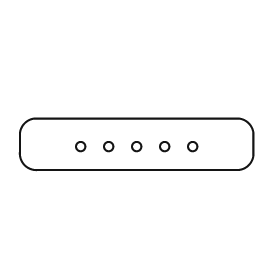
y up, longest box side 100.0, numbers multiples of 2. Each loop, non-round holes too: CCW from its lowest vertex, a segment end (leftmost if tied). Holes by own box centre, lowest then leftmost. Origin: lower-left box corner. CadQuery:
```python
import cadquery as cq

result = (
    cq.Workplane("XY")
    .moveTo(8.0, 0.0)
    .lineTo(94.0, 0.0)
    .threePointArc((98.0, 2.0), (100.0, 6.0))
    .lineTo(100.0, 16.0)
    .threePointArc((98.0, 20.0), (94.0, 22.0))
    .lineTo(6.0, 22.0)
    .threePointArc((2.0, 20.0), (0.0, 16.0))
    .lineTo(0.0, 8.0)
    .threePointArc((2.0, 2.0), (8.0, 0.0))
    .close()
    .moveTo(26.0, 10.0)
    .circle(2.0)
    .moveTo(38.0, 10.0)
    .circle(2.0)
    .moveTo(50.0, 10.0)
    .circle(2.0)
    .moveTo(62.0, 10.0)
    .circle(2.0)
    .moveTo(74.0, 10.0)
    .circle(2.0)
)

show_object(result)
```